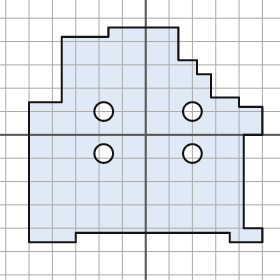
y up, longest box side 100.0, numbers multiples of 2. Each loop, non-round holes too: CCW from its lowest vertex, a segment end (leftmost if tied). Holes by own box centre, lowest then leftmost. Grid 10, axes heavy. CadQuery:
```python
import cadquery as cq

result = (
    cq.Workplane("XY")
    .moveTo(-50.0, -46.0)
    .lineTo(-30.0, -46.0)
    .lineTo(-30.0, -42.0)
    .lineTo(36.0, -42.0)
    .lineTo(36.0, -46.0)
    .lineTo(50.0, -46.0)
    .lineTo(50.0, -40.0)
    .lineTo(42.0, -40.0)
    .lineTo(42.0, 0.0)
    .lineTo(50.0, 0.0)
    .lineTo(50.0, 12.0)
    .lineTo(40.0, 12.0)
    .lineTo(40.0, 16.0)
    .lineTo(28.0, 16.0)
    .lineTo(28.0, 26.0)
    .lineTo(22.0, 26.0)
    .lineTo(22.0, 32.0)
    .lineTo(14.0, 32.0)
    .lineTo(14.0, 46.0)
    .lineTo(-16.0, 46.0)
    .lineTo(-16.0, 42.0)
    .lineTo(-36.0, 42.0)
    .lineTo(-36.0, 14.0)
    .lineTo(-50.0, 14.0)
    .close()
    .moveTo(-18.0, -8.0)
    .circle(4.0)
    .moveTo(20.0, -8.0)
    .circle(4.0)
    .moveTo(-18.0, 10.0)
    .circle(4.0)
    .moveTo(20.0, 10.0)
    .circle(4.0)
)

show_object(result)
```